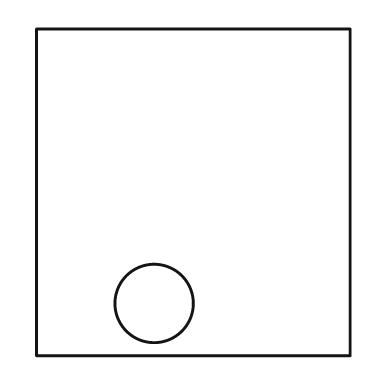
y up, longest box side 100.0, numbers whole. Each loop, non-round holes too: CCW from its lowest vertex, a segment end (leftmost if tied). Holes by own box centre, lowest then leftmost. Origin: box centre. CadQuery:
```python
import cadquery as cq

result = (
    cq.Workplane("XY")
    .moveTo(-48.0, -50.0)
    .lineTo(48.0, -50.0)
    .lineTo(48.0, 50.0)
    .lineTo(-48.0, 50.0)
    .close()
    .moveTo(-12.0, -34.0)
    .circle(12.0)
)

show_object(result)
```